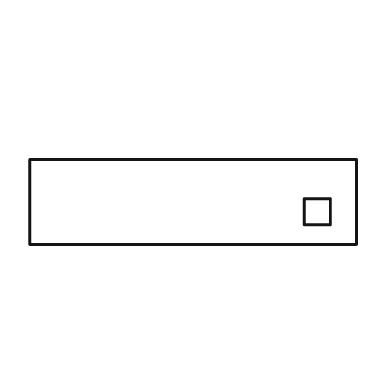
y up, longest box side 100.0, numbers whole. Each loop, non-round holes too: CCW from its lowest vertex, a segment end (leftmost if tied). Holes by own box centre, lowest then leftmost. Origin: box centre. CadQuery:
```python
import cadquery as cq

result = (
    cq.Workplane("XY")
    .moveTo(-50.0, -13.0)
    .lineTo(50.0, -13.0)
    .lineTo(50.0, 13.0)
    .lineTo(-50.0, 13.0)
    .close()
    .moveTo(34.0, -7.0)
    .lineTo(42.0, -7.0)
    .lineTo(42.0, 1.0)
    .lineTo(34.0, 1.0)
    .close()
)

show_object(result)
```